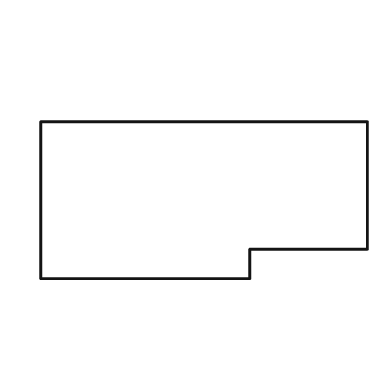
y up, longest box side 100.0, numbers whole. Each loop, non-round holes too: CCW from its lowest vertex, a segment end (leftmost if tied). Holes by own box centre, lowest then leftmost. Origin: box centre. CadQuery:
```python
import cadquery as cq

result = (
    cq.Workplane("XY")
    .moveTo(-50.0, -24.0)
    .lineTo(14.0, -24.0)
    .lineTo(14.0, -15.0)
    .lineTo(50.0, -15.0)
    .lineTo(50.0, 24.0)
    .lineTo(-50.0, 24.0)
    .close()
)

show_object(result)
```